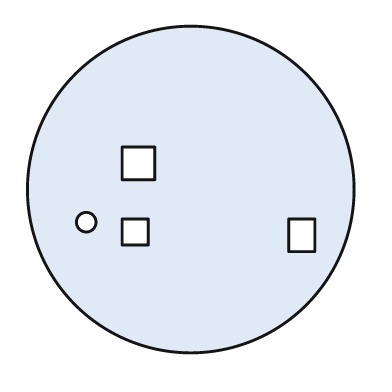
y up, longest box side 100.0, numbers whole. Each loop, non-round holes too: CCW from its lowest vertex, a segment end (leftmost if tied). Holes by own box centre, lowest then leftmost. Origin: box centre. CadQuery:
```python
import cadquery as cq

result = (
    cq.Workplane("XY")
    .moveTo(0.0, 0.0)
    .circle(50.0)
    .moveTo(30.0, -19.0)
    .lineTo(38.0, -19.0)
    .lineTo(38.0, -9.0)
    .lineTo(30.0, -9.0)
    .close()
    .moveTo(-21.0, -17.0)
    .lineTo(-13.0, -17.0)
    .lineTo(-13.0, -9.0)
    .lineTo(-21.0, -9.0)
    .close()
    .moveTo(-32.0, -10.0)
    .circle(3.0)
    .moveTo(-21.0, 3.0)
    .lineTo(-11.0, 3.0)
    .lineTo(-11.0, 13.0)
    .lineTo(-21.0, 13.0)
    .close()
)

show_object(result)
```